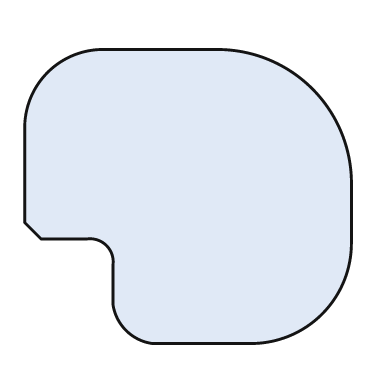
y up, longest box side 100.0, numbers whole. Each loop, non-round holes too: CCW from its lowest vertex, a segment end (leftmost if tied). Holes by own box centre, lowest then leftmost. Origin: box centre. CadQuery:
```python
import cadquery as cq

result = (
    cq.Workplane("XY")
    .moveTo(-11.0, -45.0)
    .lineTo(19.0, -45.0)
    .threePointArc((41.0, -36.0), (50.0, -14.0))
    .lineTo(50.0, 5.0)
    .threePointArc((38.0, 33.0), (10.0, 45.0))
    .lineTo(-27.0, 45.0)
    .threePointArc((-43.0, 38.0), (-50.0, 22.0))
    .lineTo(-50.0, -8.0)
    .lineTo(-45.0, -13.0)
    .lineTo(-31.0, -13.0)
    .threePointArc((-25.0, -15.0), (-23.0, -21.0))
    .lineTo(-23.0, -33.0)
    .threePointArc((-19.0, -41.0), (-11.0, -45.0))
    .close()
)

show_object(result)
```